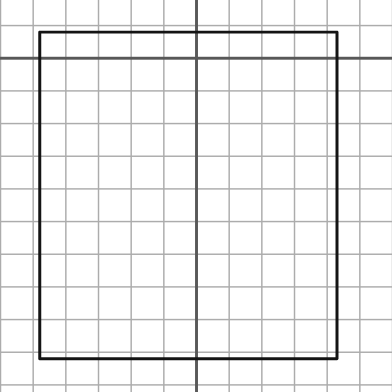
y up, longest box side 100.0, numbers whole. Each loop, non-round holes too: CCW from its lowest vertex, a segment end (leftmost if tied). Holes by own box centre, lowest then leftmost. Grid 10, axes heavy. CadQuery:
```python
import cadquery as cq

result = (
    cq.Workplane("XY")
    .moveTo(-48.0, -92.0)
    .lineTo(43.0, -92.0)
    .lineTo(43.0, 8.0)
    .lineTo(-48.0, 8.0)
    .close()
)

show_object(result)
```